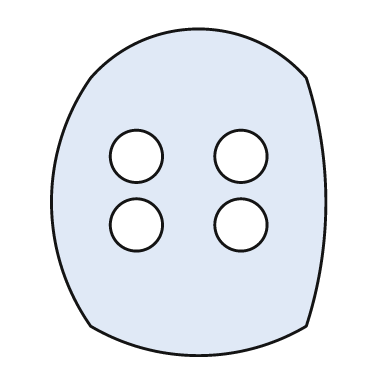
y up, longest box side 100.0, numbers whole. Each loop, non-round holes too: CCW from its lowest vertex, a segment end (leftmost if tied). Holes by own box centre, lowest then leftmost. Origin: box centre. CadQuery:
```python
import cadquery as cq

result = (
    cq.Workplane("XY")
    .moveTo(-30.0, -41.0)
    .threePointArc((3.0, -50.0), (36.0, -41.0))
    .threePointArc((42.0, -3.0), (36.0, 35.0))
    .threePointArc((3.0, 50.0), (-30.0, 35.0))
    .threePointArc((-42.0, -3.0), (-30.0, -41.0))
    .close()
    .moveTo(-16.0, -10.0)
    .circle(8.0)
    .moveTo(16.0, -10.0)
    .circle(8.0)
    .moveTo(-16.0, 11.0)
    .circle(8.0)
    .moveTo(16.0, 11.0)
    .circle(8.0)
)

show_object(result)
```